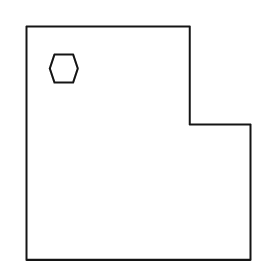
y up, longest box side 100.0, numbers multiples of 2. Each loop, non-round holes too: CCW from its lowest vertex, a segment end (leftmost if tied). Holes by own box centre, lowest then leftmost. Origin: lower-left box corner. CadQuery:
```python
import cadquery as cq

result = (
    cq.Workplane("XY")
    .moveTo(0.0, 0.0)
    .lineTo(96.0, 0.0)
    .lineTo(96.0, 58.0)
    .lineTo(70.0, 58.0)
    .lineTo(70.0, 100.0)
    .lineTo(0.0, 100.0)
    .close()
    .moveTo(12.0, 76.0)
    .lineTo(20.0, 76.0)
    .lineTo(22.0, 82.0)
    .lineTo(20.0, 88.0)
    .lineTo(12.0, 88.0)
    .lineTo(10.0, 82.0)
    .close()
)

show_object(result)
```